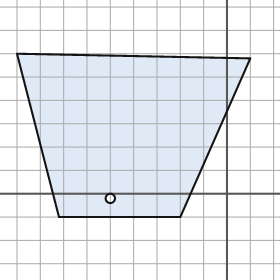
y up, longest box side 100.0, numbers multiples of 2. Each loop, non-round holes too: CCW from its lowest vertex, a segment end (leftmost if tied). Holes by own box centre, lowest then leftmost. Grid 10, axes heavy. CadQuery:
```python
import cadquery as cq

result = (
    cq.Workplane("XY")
    .moveTo(-72.0, -10.0)
    .lineTo(-20.0, -10.0)
    .lineTo(10.0, 58.0)
    .lineTo(-90.0, 60.0)
    .close()
    .moveTo(-50.0, -2.0)
    .circle(2.0)
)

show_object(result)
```